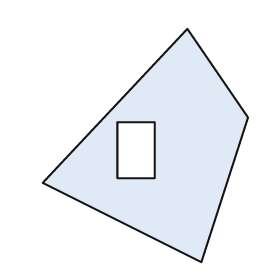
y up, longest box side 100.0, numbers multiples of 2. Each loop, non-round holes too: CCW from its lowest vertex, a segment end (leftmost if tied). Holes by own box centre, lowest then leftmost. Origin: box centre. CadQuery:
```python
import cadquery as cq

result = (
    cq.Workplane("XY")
    .moveTo(24.0, -50.0)
    .lineTo(44.0, 12.0)
    .lineTo(18.0, 50.0)
    .lineTo(-44.0, -16.0)
    .close()
    .moveTo(-12.0, -14.0)
    .lineTo(4.0, -14.0)
    .lineTo(4.0, 10.0)
    .lineTo(-12.0, 10.0)
    .close()
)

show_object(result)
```